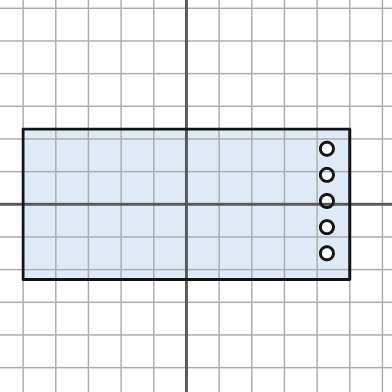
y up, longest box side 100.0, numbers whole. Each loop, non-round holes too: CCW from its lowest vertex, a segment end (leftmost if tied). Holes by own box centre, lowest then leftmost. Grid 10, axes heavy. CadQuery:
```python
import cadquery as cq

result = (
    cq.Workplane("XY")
    .moveTo(-50.0, -23.0)
    .lineTo(50.0, -23.0)
    .lineTo(50.0, 23.0)
    .lineTo(-50.0, 23.0)
    .close()
    .moveTo(43.0, -15.0)
    .circle(2.0)
    .moveTo(43.0, -7.0)
    .circle(2.0)
    .moveTo(43.0, 1.0)
    .circle(2.0)
    .moveTo(43.0, 9.0)
    .circle(2.0)
    .moveTo(43.0, 17.0)
    .circle(2.0)
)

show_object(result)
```